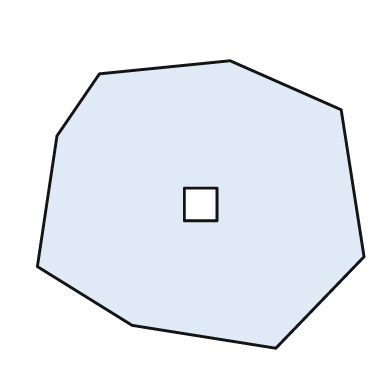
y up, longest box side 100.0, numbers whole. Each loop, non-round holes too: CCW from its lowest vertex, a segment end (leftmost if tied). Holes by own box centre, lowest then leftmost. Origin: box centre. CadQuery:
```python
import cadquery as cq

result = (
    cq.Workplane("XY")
    .moveTo(23.0, -44.0)
    .lineTo(50.0, -16.0)
    .lineTo(43.0, 29.0)
    .lineTo(9.0, 44.0)
    .lineTo(-31.0, 40.0)
    .lineTo(-44.0, 21.0)
    .lineTo(-50.0, -19.0)
    .lineTo(-21.0, -37.0)
    .close()
    .moveTo(-5.0, -5.0)
    .lineTo(5.0, -5.0)
    .lineTo(5.0, 5.0)
    .lineTo(-5.0, 5.0)
    .close()
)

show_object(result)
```